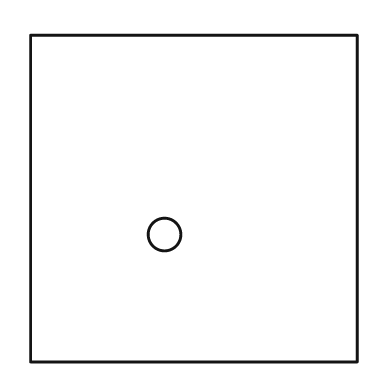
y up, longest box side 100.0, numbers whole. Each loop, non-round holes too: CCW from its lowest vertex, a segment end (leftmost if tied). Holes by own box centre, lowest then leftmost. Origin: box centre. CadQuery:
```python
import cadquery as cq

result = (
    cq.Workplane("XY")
    .moveTo(-50.0, -50.0)
    .lineTo(50.0, -50.0)
    .lineTo(50.0, 50.0)
    .lineTo(-50.0, 50.0)
    .close()
    .moveTo(-9.0, -11.0)
    .circle(5.0)
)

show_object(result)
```